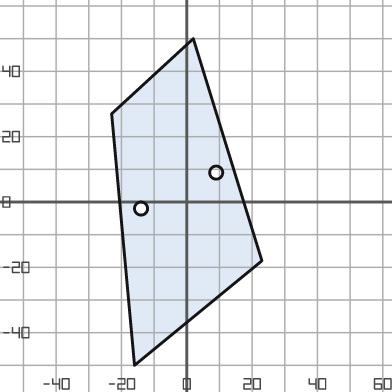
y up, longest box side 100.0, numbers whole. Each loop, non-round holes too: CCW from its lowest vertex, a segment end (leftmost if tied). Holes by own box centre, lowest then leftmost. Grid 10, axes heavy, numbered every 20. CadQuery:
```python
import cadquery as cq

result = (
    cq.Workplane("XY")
    .moveTo(-16.0, -50.0)
    .lineTo(23.0, -18.0)
    .lineTo(2.0, 50.0)
    .lineTo(-23.0, 27.0)
    .close()
    .moveTo(-14.0, -2.0)
    .circle(2.0)
    .moveTo(9.0, 9.0)
    .circle(2.0)
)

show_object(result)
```